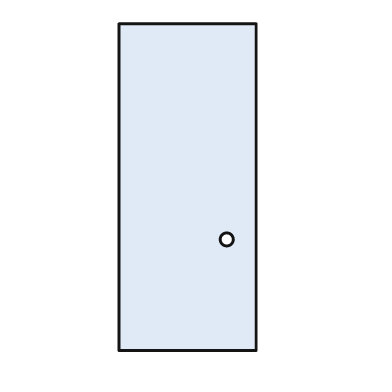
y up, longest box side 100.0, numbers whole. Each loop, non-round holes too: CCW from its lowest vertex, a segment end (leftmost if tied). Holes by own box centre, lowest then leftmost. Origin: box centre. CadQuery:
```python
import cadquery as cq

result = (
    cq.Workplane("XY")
    .moveTo(-21.0, -50.0)
    .lineTo(21.0, -50.0)
    .lineTo(21.0, 50.0)
    .lineTo(-21.0, 50.0)
    .close()
    .moveTo(12.0, -16.0)
    .circle(2.0)
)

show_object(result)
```